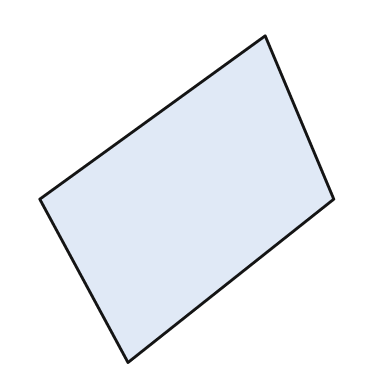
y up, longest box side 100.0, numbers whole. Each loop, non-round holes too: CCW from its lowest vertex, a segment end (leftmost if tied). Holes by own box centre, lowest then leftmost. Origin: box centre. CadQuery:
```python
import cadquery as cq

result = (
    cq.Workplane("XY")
    .moveTo(-18.0, -50.0)
    .lineTo(45.0, 0.0)
    .lineTo(24.0, 50.0)
    .lineTo(-45.0, 0.0)
    .close()
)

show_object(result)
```